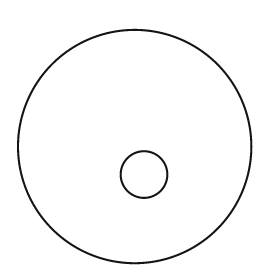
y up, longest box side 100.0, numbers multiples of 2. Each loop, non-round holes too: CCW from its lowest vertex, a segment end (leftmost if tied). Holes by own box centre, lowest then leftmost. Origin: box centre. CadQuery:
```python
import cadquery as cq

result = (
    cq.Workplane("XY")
    .moveTo(0.0, 0.0)
    .circle(50.0)
    .moveTo(4.0, -12.0)
    .circle(10.0)
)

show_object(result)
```